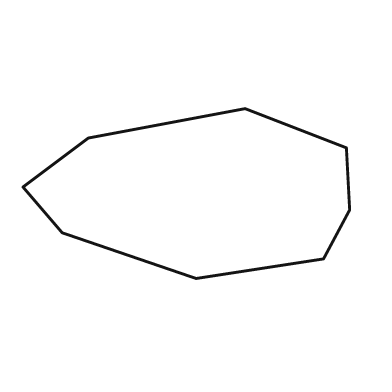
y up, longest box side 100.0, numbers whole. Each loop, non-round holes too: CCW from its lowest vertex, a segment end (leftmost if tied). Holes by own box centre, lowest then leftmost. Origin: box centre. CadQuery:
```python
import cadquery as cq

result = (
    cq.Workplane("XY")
    .moveTo(3.0, -26.0)
    .lineTo(42.0, -20.0)
    .lineTo(50.0, -5.0)
    .lineTo(49.0, 14.0)
    .lineTo(18.0, 26.0)
    .lineTo(-30.0, 17.0)
    .lineTo(-50.0, 2.0)
    .lineTo(-38.0, -12.0)
    .close()
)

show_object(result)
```